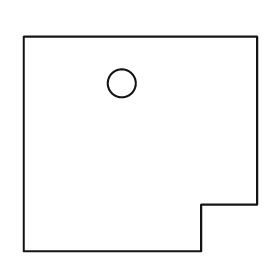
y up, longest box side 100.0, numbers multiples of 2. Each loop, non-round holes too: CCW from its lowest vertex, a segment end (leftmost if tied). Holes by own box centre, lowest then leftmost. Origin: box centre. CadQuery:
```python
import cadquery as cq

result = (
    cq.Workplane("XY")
    .moveTo(-50.0, -46.0)
    .lineTo(26.0, -46.0)
    .lineTo(26.0, -26.0)
    .lineTo(50.0, -26.0)
    .lineTo(50.0, 46.0)
    .lineTo(-50.0, 46.0)
    .close()
    .moveTo(-8.0, 26.0)
    .circle(6.0)
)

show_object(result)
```